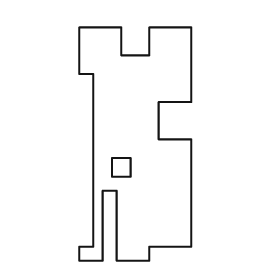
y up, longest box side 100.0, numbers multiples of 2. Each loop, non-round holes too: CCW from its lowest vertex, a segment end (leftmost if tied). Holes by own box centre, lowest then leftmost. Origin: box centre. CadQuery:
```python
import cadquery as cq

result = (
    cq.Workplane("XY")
    .moveTo(-24.0, -50.0)
    .lineTo(-14.0, -50.0)
    .lineTo(-14.0, -20.0)
    .lineTo(-8.0, -20.0)
    .lineTo(-8.0, -50.0)
    .lineTo(6.0, -50.0)
    .lineTo(6.0, -44.0)
    .lineTo(24.0, -44.0)
    .lineTo(24.0, 2.0)
    .lineTo(10.0, 2.0)
    .lineTo(10.0, 18.0)
    .lineTo(24.0, 18.0)
    .lineTo(24.0, 50.0)
    .lineTo(6.0, 50.0)
    .lineTo(6.0, 38.0)
    .lineTo(-6.0, 38.0)
    .lineTo(-6.0, 50.0)
    .lineTo(-24.0, 50.0)
    .lineTo(-24.0, 30.0)
    .lineTo(-18.0, 30.0)
    .lineTo(-18.0, -44.0)
    .lineTo(-24.0, -44.0)
    .close()
    .moveTo(-10.0, -14.0)
    .lineTo(-2.0, -14.0)
    .lineTo(-2.0, -6.0)
    .lineTo(-10.0, -6.0)
    .close()
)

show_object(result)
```